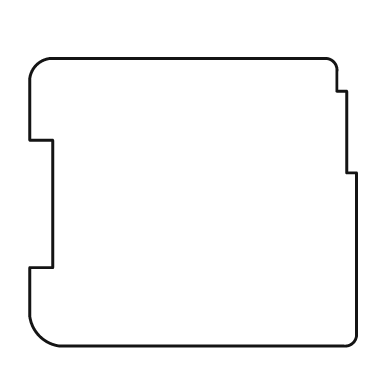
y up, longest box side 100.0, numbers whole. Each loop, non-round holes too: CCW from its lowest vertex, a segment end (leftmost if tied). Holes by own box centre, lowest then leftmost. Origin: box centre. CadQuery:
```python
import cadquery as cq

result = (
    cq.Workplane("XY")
    .moveTo(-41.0, -44.0)
    .lineTo(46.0, -44.0)
    .threePointArc((49.0, -43.0), (50.0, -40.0))
    .lineTo(50.0, 9.0)
    .lineTo(47.0, 9.0)
    .lineTo(47.0, 34.0)
    .lineTo(44.0, 34.0)
    .lineTo(44.0, 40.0)
    .threePointArc((43.0, 43.0), (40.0, 44.0))
    .lineTo(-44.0, 44.0)
    .threePointArc((-48.0, 42.0), (-50.0, 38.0))
    .lineTo(-50.0, 19.0)
    .lineTo(-43.0, 19.0)
    .lineTo(-43.0, -20.0)
    .lineTo(-50.0, -20.0)
    .lineTo(-50.0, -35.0)
    .threePointArc((-47.0, -41.0), (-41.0, -44.0))
    .close()
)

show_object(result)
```